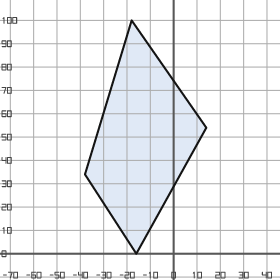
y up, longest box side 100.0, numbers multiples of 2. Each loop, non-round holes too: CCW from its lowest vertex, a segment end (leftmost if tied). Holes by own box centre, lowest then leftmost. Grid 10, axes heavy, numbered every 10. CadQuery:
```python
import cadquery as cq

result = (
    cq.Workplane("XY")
    .moveTo(-16.0, 0.0)
    .lineTo(14.0, 54.0)
    .lineTo(-18.0, 100.0)
    .lineTo(-38.0, 34.0)
    .close()
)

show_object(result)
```